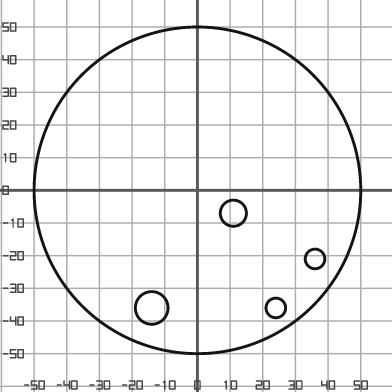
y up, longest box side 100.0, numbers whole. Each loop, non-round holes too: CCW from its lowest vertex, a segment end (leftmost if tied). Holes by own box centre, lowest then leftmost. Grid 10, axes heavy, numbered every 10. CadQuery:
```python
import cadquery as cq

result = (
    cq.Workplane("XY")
    .moveTo(0.0, 0.0)
    .circle(50.0)
    .moveTo(-14.0, -36.0)
    .circle(5.0)
    .moveTo(24.0, -36.0)
    .circle(3.0)
    .moveTo(36.0, -21.0)
    .circle(3.0)
    .moveTo(11.0, -7.0)
    .circle(4.0)
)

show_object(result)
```